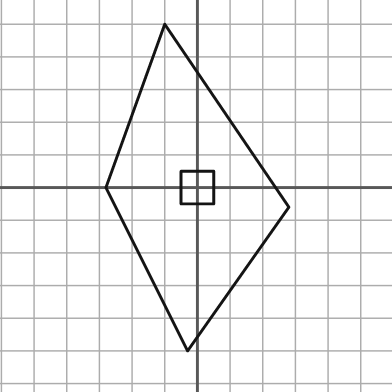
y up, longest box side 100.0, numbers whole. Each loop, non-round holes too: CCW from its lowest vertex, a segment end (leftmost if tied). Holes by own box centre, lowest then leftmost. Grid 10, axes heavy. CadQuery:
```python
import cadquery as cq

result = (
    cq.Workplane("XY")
    .moveTo(-3.0, -50.0)
    .lineTo(28.0, -6.0)
    .lineTo(-10.0, 50.0)
    .lineTo(-28.0, 0.0)
    .close()
    .moveTo(-5.0, -5.0)
    .lineTo(5.0, -5.0)
    .lineTo(5.0, 5.0)
    .lineTo(-5.0, 5.0)
    .close()
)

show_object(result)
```